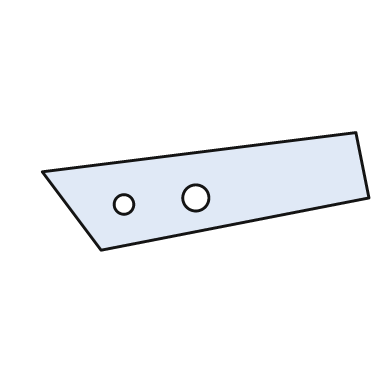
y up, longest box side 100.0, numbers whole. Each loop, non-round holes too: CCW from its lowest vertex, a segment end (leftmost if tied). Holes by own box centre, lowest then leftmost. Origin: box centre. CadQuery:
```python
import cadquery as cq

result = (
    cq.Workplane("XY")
    .moveTo(-32.0, -18.0)
    .lineTo(50.0, -2.0)
    .lineTo(46.0, 18.0)
    .lineTo(-50.0, 6.0)
    .close()
    .moveTo(-25.0, -4.0)
    .circle(3.0)
    .moveTo(-3.0, -2.0)
    .circle(4.0)
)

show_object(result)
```